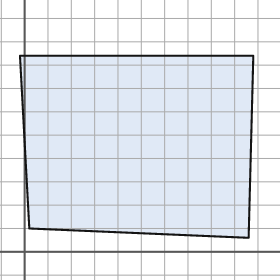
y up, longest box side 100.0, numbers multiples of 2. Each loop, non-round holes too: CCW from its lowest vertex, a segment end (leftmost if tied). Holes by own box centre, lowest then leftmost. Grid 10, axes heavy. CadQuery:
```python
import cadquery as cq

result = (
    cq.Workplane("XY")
    .moveTo(96.0, 6.0)
    .lineTo(98.0, 84.0)
    .lineTo(-2.0, 84.0)
    .lineTo(2.0, 10.0)
    .close()
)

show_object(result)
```